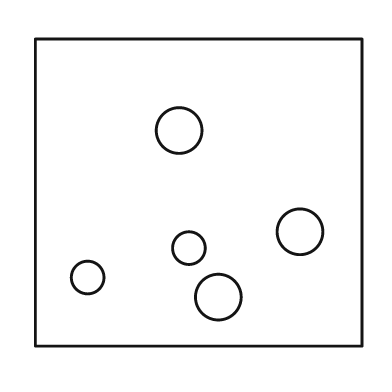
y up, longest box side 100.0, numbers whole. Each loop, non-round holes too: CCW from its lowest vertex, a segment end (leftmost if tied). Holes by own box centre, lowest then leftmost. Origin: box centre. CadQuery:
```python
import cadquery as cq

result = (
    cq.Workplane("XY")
    .moveTo(-50.0, -47.0)
    .lineTo(50.0, -47.0)
    .lineTo(50.0, 47.0)
    .lineTo(-50.0, 47.0)
    .close()
    .moveTo(6.0, -32.0)
    .circle(7.0)
    .moveTo(-34.0, -26.0)
    .circle(5.0)
    .moveTo(-3.0, -17.0)
    .circle(5.0)
    .moveTo(31.0, -12.0)
    .circle(7.0)
    .moveTo(-6.0, 19.0)
    .circle(7.0)
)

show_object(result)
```